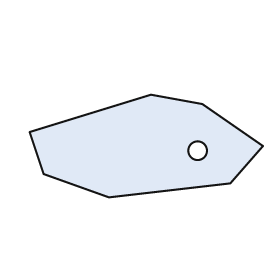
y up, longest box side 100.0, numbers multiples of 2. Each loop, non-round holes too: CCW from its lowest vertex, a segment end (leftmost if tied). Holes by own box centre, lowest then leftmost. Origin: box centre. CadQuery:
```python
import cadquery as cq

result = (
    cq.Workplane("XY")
    .moveTo(-16.0, -22.0)
    .lineTo(36.0, -16.0)
    .lineTo(50.0, 0.0)
    .lineTo(24.0, 18.0)
    .lineTo(2.0, 22.0)
    .lineTo(-50.0, 6.0)
    .lineTo(-44.0, -12.0)
    .close()
    .moveTo(22.0, -2.0)
    .circle(4.0)
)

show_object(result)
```